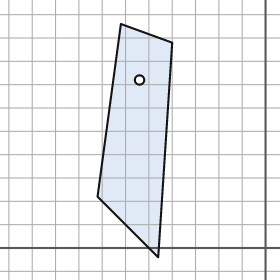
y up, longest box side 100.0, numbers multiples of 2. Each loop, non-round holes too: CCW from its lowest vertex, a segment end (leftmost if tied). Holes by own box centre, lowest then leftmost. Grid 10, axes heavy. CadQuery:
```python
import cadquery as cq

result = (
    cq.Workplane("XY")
    .moveTo(-46.0, -4.0)
    .lineTo(-40.0, 88.0)
    .lineTo(-62.0, 96.0)
    .lineTo(-72.0, 22.0)
    .close()
    .moveTo(-54.0, 72.0)
    .circle(2.0)
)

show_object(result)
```